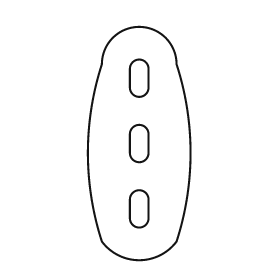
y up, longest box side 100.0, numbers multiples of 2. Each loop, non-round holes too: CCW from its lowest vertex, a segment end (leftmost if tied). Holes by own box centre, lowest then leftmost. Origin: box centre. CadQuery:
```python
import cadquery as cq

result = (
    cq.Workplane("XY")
    .moveTo(-16.0, -42.0)
    .threePointArc((0.0, -50.0), (16.0, -42.0))
    .threePointArc((22.0, -4.0), (16.0, 34.0))
    .threePointArc((0.0, 50.0), (-16.0, 34.0))
    .threePointArc((-22.0, -4.0), (-16.0, -42.0))
    .close()
    .moveTo(-4.0, -32.0)
    .threePointArc((0.0, -36.0), (4.0, -32.0))
    .lineTo(4.0, -24.0)
    .threePointArc((0.0, -20.0), (-4.0, -24.0))
    .close()
    .moveTo(-4.0, -4.0)
    .threePointArc((0.0, -8.0), (4.0, -4.0))
    .lineTo(4.0, 4.0)
    .threePointArc((0.0, 8.0), (-4.0, 4.0))
    .close()
    .moveTo(-4.0, 24.0)
    .threePointArc((0.0, 20.0), (4.0, 24.0))
    .lineTo(4.0, 32.0)
    .threePointArc((0.0, 36.0), (-4.0, 32.0))
    .close()
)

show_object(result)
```